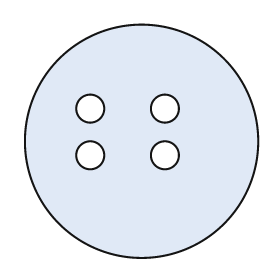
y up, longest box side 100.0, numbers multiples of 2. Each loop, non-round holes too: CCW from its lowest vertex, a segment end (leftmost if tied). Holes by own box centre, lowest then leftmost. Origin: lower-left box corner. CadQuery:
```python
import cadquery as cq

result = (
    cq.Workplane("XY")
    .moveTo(50.0, 50.0)
    .circle(50.0)
    .moveTo(28.0, 44.0)
    .circle(6.0)
    .moveTo(60.0, 44.0)
    .circle(6.0)
    .moveTo(28.0, 64.0)
    .circle(6.0)
    .moveTo(60.0, 64.0)
    .circle(6.0)
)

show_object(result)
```